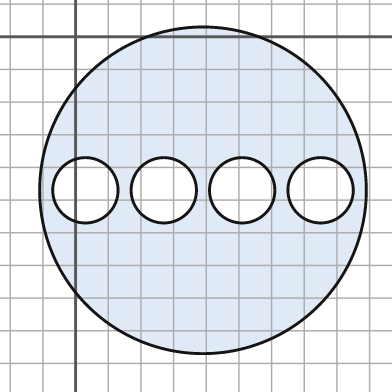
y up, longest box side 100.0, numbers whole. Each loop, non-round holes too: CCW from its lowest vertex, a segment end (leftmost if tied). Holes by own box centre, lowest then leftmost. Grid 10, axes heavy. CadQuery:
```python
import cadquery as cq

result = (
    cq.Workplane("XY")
    .moveTo(39.0, -47.0)
    .circle(50.0)
    .moveTo(3.0, -47.0)
    .circle(10.0)
    .moveTo(27.0, -47.0)
    .circle(10.0)
    .moveTo(51.0, -47.0)
    .circle(10.0)
    .moveTo(75.0, -47.0)
    .circle(10.0)
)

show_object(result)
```